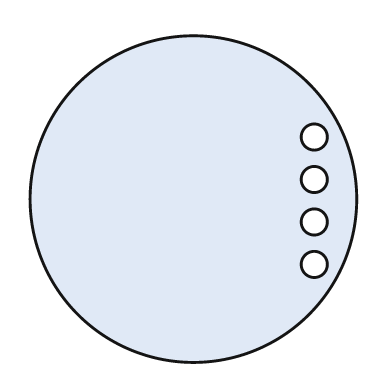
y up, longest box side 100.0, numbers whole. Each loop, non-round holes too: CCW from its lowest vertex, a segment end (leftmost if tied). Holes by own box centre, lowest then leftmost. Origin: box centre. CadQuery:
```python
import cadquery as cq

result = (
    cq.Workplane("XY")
    .moveTo(0.0, 0.0)
    .circle(50.0)
    .moveTo(37.0, -20.0)
    .circle(4.0)
    .moveTo(37.0, -7.0)
    .circle(4.0)
    .moveTo(37.0, 6.0)
    .circle(4.0)
    .moveTo(37.0, 19.0)
    .circle(4.0)
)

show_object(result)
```